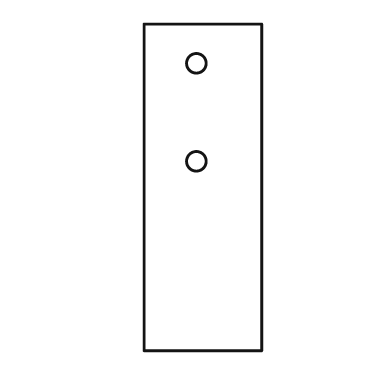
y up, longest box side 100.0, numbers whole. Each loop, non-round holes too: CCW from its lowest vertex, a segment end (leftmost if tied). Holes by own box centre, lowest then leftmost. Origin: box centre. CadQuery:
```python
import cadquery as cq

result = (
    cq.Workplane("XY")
    .moveTo(-18.0, -50.0)
    .lineTo(18.0, -50.0)
    .lineTo(18.0, 50.0)
    .lineTo(-18.0, 50.0)
    .close()
    .moveTo(-2.0, 8.0)
    .circle(3.0)
    .moveTo(-2.0, 38.0)
    .circle(3.0)
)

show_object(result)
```